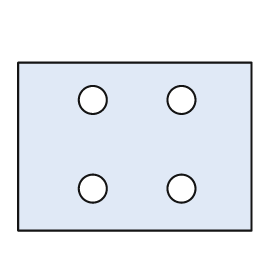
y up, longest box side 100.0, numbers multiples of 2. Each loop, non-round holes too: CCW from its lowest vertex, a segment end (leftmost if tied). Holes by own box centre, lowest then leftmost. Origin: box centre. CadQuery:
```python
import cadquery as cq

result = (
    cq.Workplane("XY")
    .moveTo(-50.0, -36.0)
    .lineTo(50.0, -36.0)
    .lineTo(50.0, 36.0)
    .lineTo(-50.0, 36.0)
    .close()
    .moveTo(-18.0, -18.0)
    .circle(6.0)
    .moveTo(20.0, -18.0)
    .circle(6.0)
    .moveTo(-18.0, 20.0)
    .circle(6.0)
    .moveTo(20.0, 20.0)
    .circle(6.0)
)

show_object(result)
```